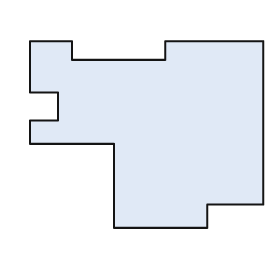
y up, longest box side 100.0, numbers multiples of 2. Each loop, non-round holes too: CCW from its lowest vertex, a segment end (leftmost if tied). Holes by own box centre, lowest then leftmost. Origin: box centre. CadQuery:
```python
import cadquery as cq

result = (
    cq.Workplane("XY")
    .moveTo(-14.0, -40.0)
    .lineTo(26.0, -40.0)
    .lineTo(26.0, -30.0)
    .lineTo(50.0, -30.0)
    .lineTo(50.0, 40.0)
    .lineTo(8.0, 40.0)
    .lineTo(8.0, 32.0)
    .lineTo(-32.0, 32.0)
    .lineTo(-32.0, 40.0)
    .lineTo(-50.0, 40.0)
    .lineTo(-50.0, 18.0)
    .lineTo(-38.0, 18.0)
    .lineTo(-38.0, 6.0)
    .lineTo(-50.0, 6.0)
    .lineTo(-50.0, -4.0)
    .lineTo(-14.0, -4.0)
    .close()
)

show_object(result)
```